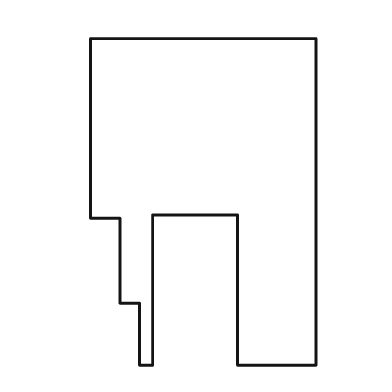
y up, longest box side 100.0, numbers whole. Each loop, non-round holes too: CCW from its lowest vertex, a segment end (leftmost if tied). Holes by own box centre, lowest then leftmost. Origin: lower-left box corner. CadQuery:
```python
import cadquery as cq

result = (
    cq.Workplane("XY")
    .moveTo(15.0, 0.0)
    .lineTo(19.0, 0.0)
    .lineTo(19.0, 46.0)
    .lineTo(45.0, 46.0)
    .lineTo(45.0, 0.0)
    .lineTo(69.0, 0.0)
    .lineTo(69.0, 100.0)
    .lineTo(0.0, 100.0)
    .lineTo(0.0, 45.0)
    .lineTo(9.0, 45.0)
    .lineTo(9.0, 19.0)
    .lineTo(15.0, 19.0)
    .close()
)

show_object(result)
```